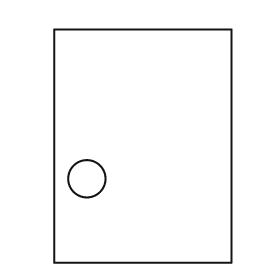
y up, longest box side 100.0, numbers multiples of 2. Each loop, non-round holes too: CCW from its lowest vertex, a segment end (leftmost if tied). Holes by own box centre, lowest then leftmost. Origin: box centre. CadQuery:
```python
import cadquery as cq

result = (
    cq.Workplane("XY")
    .moveTo(-38.0, -50.0)
    .lineTo(38.0, -50.0)
    .lineTo(38.0, 50.0)
    .lineTo(-38.0, 50.0)
    .close()
    .moveTo(-24.0, -14.0)
    .circle(8.0)
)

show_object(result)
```